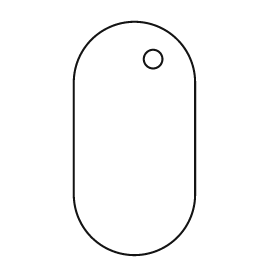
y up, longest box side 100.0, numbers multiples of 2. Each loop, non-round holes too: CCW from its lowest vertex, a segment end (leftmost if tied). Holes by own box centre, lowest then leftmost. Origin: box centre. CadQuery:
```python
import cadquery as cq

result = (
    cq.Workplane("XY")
    .moveTo(-26.0, -24.0)
    .threePointArc((0.0, -50.0), (26.0, -24.0))
    .lineTo(26.0, 24.0)
    .threePointArc((0.0, 50.0), (-26.0, 24.0))
    .close()
    .moveTo(8.0, 34.0)
    .circle(4.0)
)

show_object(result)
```